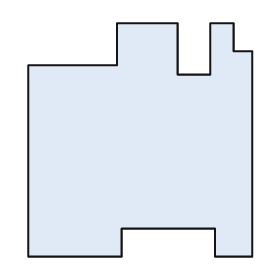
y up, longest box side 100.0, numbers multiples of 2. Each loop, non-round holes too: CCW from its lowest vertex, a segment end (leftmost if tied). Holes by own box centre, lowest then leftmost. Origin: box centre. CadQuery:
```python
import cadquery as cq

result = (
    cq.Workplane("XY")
    .moveTo(-48.0, -50.0)
    .lineTo(-8.0, -50.0)
    .lineTo(-8.0, -38.0)
    .lineTo(32.0, -38.0)
    .lineTo(32.0, -50.0)
    .lineTo(48.0, -50.0)
    .lineTo(48.0, 38.0)
    .lineTo(40.0, 38.0)
    .lineTo(40.0, 50.0)
    .lineTo(30.0, 50.0)
    .lineTo(30.0, 28.0)
    .lineTo(16.0, 28.0)
    .lineTo(16.0, 50.0)
    .lineTo(-10.0, 50.0)
    .lineTo(-10.0, 32.0)
    .lineTo(-48.0, 32.0)
    .close()
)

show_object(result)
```